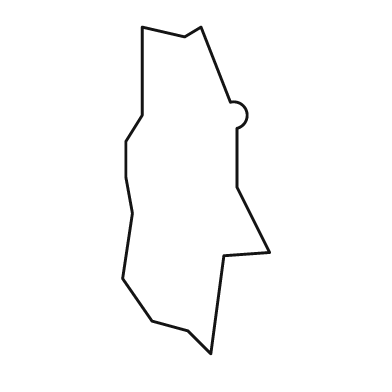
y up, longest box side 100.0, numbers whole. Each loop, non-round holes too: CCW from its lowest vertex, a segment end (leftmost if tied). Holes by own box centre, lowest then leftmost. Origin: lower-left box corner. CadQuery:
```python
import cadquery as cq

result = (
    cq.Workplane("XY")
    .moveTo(27.0, 0.0)
    .lineTo(31.0, 30.0)
    .lineTo(45.0, 31.0)
    .lineTo(35.0, 51.0)
    .lineTo(35.0, 69.0)
    .threePointArc((38.0, 74.0), (33.0, 77.0))
    .lineTo(24.0, 100.0)
    .lineTo(19.0, 97.0)
    .lineTo(6.0, 100.0)
    .lineTo(6.0, 73.0)
    .lineTo(1.0, 65.0)
    .lineTo(1.0, 54.0)
    .lineTo(3.0, 43.0)
    .lineTo(0.0, 23.0)
    .lineTo(9.0, 10.0)
    .lineTo(20.0, 7.0)
    .close()
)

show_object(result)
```